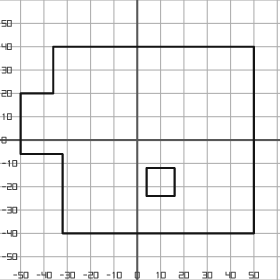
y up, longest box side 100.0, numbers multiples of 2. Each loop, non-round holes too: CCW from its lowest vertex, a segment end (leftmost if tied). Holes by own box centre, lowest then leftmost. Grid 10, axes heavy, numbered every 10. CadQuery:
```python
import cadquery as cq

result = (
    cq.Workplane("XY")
    .moveTo(-32.0, -40.0)
    .lineTo(50.0, -40.0)
    .lineTo(50.0, 40.0)
    .lineTo(-36.0, 40.0)
    .lineTo(-36.0, 20.0)
    .lineTo(-50.0, 20.0)
    .lineTo(-50.0, -6.0)
    .lineTo(-32.0, -6.0)
    .close()
    .moveTo(4.0, -24.0)
    .lineTo(16.0, -24.0)
    .lineTo(16.0, -12.0)
    .lineTo(4.0, -12.0)
    .close()
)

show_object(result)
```